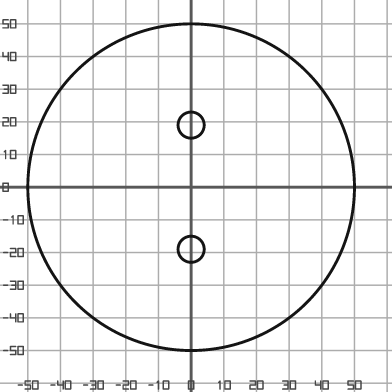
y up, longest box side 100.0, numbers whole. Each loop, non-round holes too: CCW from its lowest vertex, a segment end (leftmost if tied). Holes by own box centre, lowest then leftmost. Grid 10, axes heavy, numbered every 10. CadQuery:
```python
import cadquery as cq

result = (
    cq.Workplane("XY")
    .moveTo(0.0, 0.0)
    .circle(50.0)
    .moveTo(0.0, -19.0)
    .circle(4.0)
    .moveTo(0.0, 19.0)
    .circle(4.0)
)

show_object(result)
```